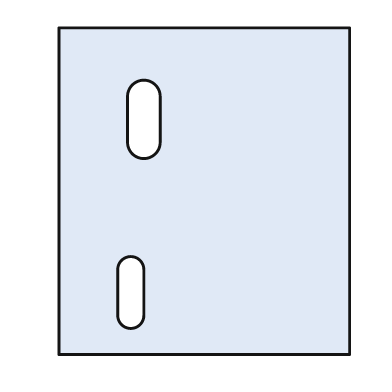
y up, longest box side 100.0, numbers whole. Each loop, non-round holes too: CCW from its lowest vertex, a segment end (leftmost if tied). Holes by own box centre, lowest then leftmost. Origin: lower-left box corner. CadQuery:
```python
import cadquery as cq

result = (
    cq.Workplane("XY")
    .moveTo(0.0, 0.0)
    .lineTo(89.0, 0.0)
    .lineTo(89.0, 100.0)
    .lineTo(0.0, 100.0)
    .close()
    .moveTo(18.0, 12.0)
    .threePointArc((22.0, 8.0), (26.0, 12.0))
    .lineTo(26.0, 26.0)
    .threePointArc((22.0, 30.0), (18.0, 26.0))
    .close()
    .moveTo(21.0, 65.0)
    .threePointArc((26.0, 60.0), (31.0, 65.0))
    .lineTo(31.0, 79.0)
    .threePointArc((26.0, 84.0), (21.0, 79.0))
    .close()
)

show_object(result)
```